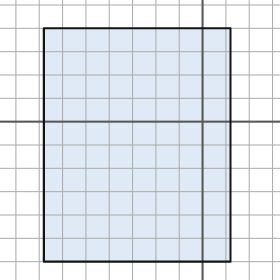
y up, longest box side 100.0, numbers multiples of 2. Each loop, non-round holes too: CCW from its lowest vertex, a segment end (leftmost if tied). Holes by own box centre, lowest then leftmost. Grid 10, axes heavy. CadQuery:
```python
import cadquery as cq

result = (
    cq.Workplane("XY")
    .moveTo(-68.0, -60.0)
    .lineTo(12.0, -60.0)
    .lineTo(12.0, 40.0)
    .lineTo(-68.0, 40.0)
    .close()
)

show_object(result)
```